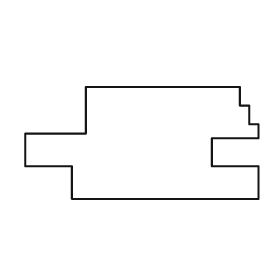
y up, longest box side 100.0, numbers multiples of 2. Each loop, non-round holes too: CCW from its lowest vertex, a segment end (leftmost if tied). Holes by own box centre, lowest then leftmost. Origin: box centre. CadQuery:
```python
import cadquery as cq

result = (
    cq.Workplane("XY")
    .moveTo(-30.0, -24.0)
    .lineTo(50.0, -24.0)
    .lineTo(50.0, -10.0)
    .lineTo(30.0, -10.0)
    .lineTo(30.0, 2.0)
    .lineTo(50.0, 2.0)
    .lineTo(50.0, 8.0)
    .lineTo(46.0, 8.0)
    .lineTo(46.0, 16.0)
    .lineTo(42.0, 16.0)
    .lineTo(42.0, 24.0)
    .lineTo(-24.0, 24.0)
    .lineTo(-24.0, 4.0)
    .lineTo(-50.0, 4.0)
    .lineTo(-50.0, -10.0)
    .lineTo(-30.0, -10.0)
    .close()
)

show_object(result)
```